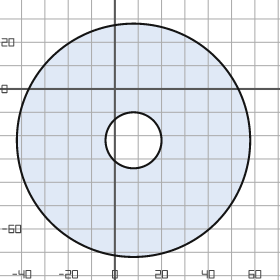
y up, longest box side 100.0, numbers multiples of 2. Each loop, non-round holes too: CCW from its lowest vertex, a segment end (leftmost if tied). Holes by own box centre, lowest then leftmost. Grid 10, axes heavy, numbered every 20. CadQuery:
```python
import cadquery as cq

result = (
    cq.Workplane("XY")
    .moveTo(8.0, -22.0)
    .circle(50.0)
    .moveTo(8.0, -22.0)
    .circle(12.0)
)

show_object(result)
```